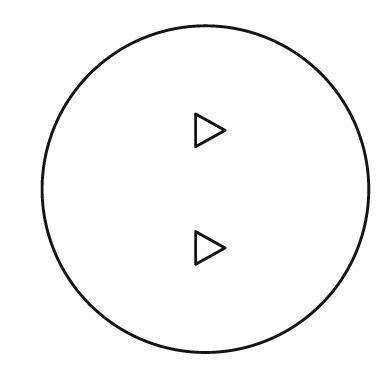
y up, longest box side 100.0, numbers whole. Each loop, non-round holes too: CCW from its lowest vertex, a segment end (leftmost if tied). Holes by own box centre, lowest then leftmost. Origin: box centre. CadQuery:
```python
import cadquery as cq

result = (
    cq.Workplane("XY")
    .moveTo(0.0, 0.0)
    .circle(50.0)
    .moveTo(-3.0, -23.0)
    .lineTo(6.0, -18.0)
    .lineTo(-3.0, -13.0)
    .close()
    .moveTo(-3.0, 13.0)
    .lineTo(6.0, 18.0)
    .lineTo(-3.0, 23.0)
    .close()
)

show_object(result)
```